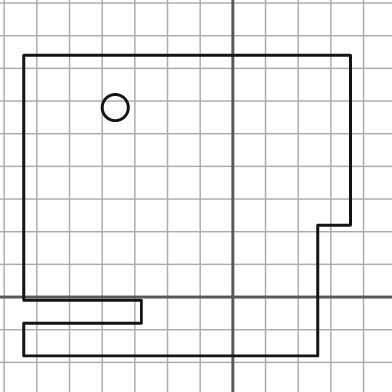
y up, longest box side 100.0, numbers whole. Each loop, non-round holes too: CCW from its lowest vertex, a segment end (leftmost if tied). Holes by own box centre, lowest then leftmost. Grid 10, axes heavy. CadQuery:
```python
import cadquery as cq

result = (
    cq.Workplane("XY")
    .moveTo(-64.0, -18.0)
    .lineTo(26.0, -18.0)
    .lineTo(26.0, 22.0)
    .lineTo(36.0, 22.0)
    .lineTo(36.0, 74.0)
    .lineTo(-64.0, 74.0)
    .lineTo(-64.0, -1.0)
    .lineTo(-28.0, -1.0)
    .lineTo(-28.0, -8.0)
    .lineTo(-64.0, -8.0)
    .close()
    .moveTo(-36.0, 58.0)
    .circle(4.0)
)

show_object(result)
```